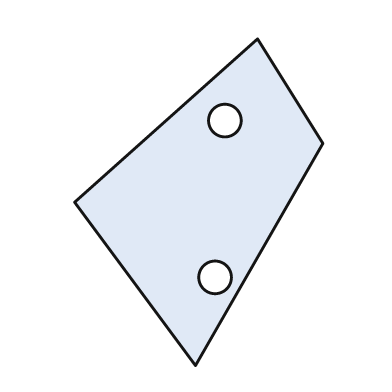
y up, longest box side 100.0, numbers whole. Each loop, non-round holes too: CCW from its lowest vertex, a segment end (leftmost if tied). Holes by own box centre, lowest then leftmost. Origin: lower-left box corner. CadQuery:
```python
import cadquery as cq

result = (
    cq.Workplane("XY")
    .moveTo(37.0, 0.0)
    .lineTo(76.0, 68.0)
    .lineTo(56.0, 100.0)
    .lineTo(0.0, 50.0)
    .close()
    .moveTo(43.0, 27.0)
    .circle(5.0)
    .moveTo(46.0, 75.0)
    .circle(5.0)
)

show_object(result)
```